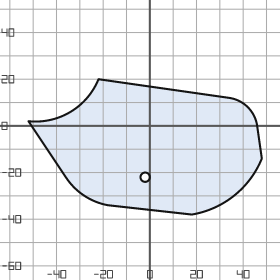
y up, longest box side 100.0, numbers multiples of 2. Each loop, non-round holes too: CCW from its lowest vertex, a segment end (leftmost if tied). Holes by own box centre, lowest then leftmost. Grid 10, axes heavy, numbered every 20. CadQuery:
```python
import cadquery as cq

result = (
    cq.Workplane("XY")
    .moveTo(18.0, -38.0)
    .threePointArc((36.0, -30.0), (48.0, -14.0))
    .lineTo(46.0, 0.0)
    .threePointArc((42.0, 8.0), (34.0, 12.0))
    .lineTo(-22.0, 20.0)
    .threePointArc((-34.0, 6.0), (-52.0, 2.0))
    .lineTo(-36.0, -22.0)
    .threePointArc((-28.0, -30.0), (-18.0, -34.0))
    .close()
    .moveTo(-2.0, -22.0)
    .circle(2.0)
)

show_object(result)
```